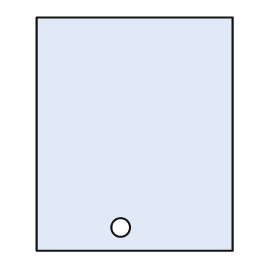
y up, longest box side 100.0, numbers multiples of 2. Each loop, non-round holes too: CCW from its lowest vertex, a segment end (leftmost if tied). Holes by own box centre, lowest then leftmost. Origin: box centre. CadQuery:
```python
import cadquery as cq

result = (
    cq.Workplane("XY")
    .moveTo(-42.0, -50.0)
    .lineTo(42.0, -50.0)
    .lineTo(42.0, 50.0)
    .lineTo(-42.0, 50.0)
    .close()
    .moveTo(-6.0, -40.0)
    .circle(4.0)
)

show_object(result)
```